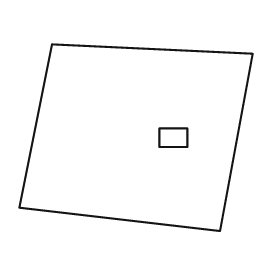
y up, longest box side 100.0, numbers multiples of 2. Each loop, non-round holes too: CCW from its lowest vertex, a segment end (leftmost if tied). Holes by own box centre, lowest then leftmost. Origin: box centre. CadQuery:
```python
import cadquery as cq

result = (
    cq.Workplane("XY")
    .moveTo(36.0, -40.0)
    .lineTo(50.0, 36.0)
    .lineTo(-36.0, 40.0)
    .lineTo(-50.0, -30.0)
    .close()
    .moveTo(10.0, -4.0)
    .lineTo(22.0, -4.0)
    .lineTo(22.0, 4.0)
    .lineTo(10.0, 4.0)
    .close()
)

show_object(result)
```